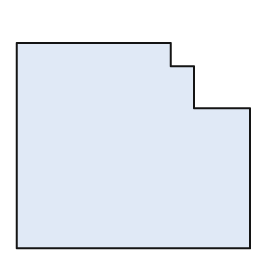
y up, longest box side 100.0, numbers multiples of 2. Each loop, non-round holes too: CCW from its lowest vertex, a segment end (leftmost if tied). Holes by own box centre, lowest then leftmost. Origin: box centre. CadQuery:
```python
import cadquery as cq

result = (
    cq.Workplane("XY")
    .moveTo(-50.0, -44.0)
    .lineTo(50.0, -44.0)
    .lineTo(50.0, 16.0)
    .lineTo(26.0, 16.0)
    .lineTo(26.0, 34.0)
    .lineTo(16.0, 34.0)
    .lineTo(16.0, 44.0)
    .lineTo(-50.0, 44.0)
    .close()
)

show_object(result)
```